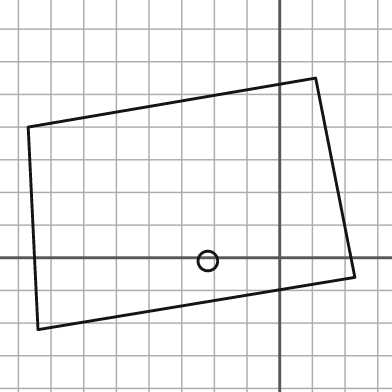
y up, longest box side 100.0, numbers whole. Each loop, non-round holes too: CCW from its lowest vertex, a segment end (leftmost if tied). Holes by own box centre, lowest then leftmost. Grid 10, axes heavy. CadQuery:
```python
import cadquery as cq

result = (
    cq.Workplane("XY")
    .moveTo(-74.0, -22.0)
    .lineTo(23.0, -6.0)
    .lineTo(11.0, 55.0)
    .lineTo(-77.0, 40.0)
    .close()
    .moveTo(-22.0, -1.0)
    .circle(3.0)
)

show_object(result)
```